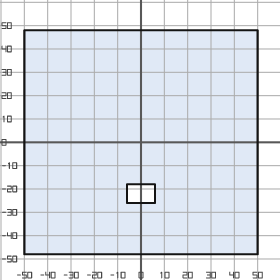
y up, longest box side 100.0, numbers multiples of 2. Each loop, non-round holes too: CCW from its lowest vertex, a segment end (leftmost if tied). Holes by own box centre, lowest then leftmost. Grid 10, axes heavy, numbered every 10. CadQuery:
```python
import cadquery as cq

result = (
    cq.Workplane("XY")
    .moveTo(-50.0, -48.0)
    .lineTo(50.0, -48.0)
    .lineTo(50.0, 48.0)
    .lineTo(-50.0, 48.0)
    .close()
    .moveTo(-6.0, -26.0)
    .lineTo(6.0, -26.0)
    .lineTo(6.0, -18.0)
    .lineTo(-6.0, -18.0)
    .close()
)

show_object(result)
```